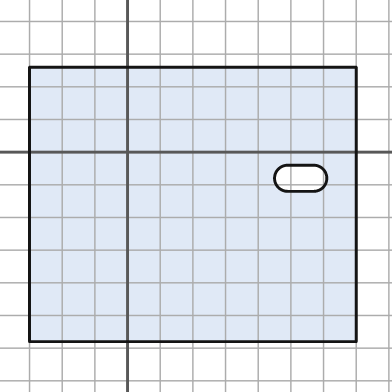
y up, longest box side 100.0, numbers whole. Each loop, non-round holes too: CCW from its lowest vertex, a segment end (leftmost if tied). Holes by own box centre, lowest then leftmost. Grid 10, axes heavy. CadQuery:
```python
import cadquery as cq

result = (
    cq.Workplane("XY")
    .moveTo(-30.0, -58.0)
    .lineTo(70.0, -58.0)
    .lineTo(70.0, 26.0)
    .lineTo(-30.0, 26.0)
    .close()
    .moveTo(49.0, -12.0)
    .lineTo(57.0, -12.0)
    .threePointArc((61.0, -8.0), (57.0, -4.0))
    .lineTo(49.0, -4.0)
    .threePointArc((45.0, -8.0), (49.0, -12.0))
    .close()
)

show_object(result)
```